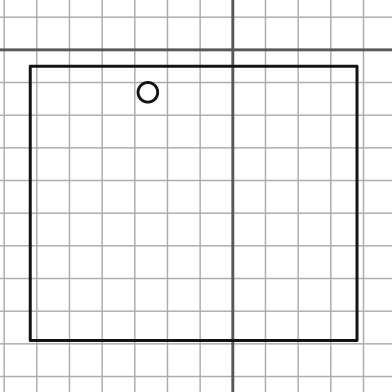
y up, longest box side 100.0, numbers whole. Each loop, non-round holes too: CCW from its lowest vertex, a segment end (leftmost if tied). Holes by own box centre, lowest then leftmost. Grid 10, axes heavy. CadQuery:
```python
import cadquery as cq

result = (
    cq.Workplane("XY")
    .moveTo(-62.0, -89.0)
    .lineTo(38.0, -89.0)
    .lineTo(38.0, -5.0)
    .lineTo(-62.0, -5.0)
    .close()
    .moveTo(-26.0, -13.0)
    .circle(3.0)
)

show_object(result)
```